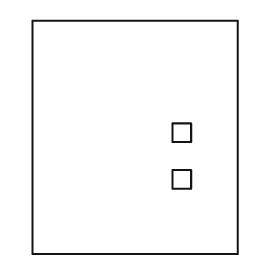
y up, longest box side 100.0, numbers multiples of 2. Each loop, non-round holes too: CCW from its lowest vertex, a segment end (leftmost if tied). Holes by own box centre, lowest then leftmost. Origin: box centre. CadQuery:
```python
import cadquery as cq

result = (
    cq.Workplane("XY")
    .moveTo(-44.0, -50.0)
    .lineTo(44.0, -50.0)
    .lineTo(44.0, 50.0)
    .lineTo(-44.0, 50.0)
    .close()
    .moveTo(16.0, -22.0)
    .lineTo(24.0, -22.0)
    .lineTo(24.0, -14.0)
    .lineTo(16.0, -14.0)
    .close()
    .moveTo(16.0, -2.0)
    .lineTo(24.0, -2.0)
    .lineTo(24.0, 6.0)
    .lineTo(16.0, 6.0)
    .close()
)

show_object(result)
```